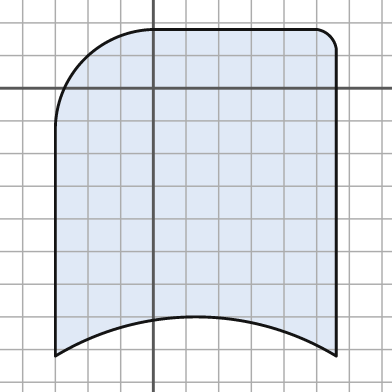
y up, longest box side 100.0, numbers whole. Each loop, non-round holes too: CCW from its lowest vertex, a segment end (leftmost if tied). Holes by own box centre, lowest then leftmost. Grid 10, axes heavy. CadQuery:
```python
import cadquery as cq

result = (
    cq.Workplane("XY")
    .moveTo(-30.0, -82.0)
    .threePointArc((13.0, -70.0), (56.0, -82.0))
    .lineTo(56.0, 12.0)
    .threePointArc((54.0, 16.0), (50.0, 18.0))
    .lineTo(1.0, 18.0)
    .threePointArc((-21.0, 9.0), (-30.0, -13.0))
    .close()
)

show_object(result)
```